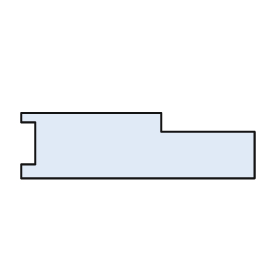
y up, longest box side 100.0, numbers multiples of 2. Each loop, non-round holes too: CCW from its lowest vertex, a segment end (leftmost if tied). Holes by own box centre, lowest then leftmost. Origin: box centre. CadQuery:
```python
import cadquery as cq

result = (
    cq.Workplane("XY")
    .moveTo(-50.0, -14.0)
    .lineTo(50.0, -14.0)
    .lineTo(50.0, 6.0)
    .lineTo(10.0, 6.0)
    .lineTo(10.0, 14.0)
    .lineTo(-50.0, 14.0)
    .lineTo(-50.0, 10.0)
    .lineTo(-44.0, 10.0)
    .lineTo(-44.0, -8.0)
    .lineTo(-50.0, -8.0)
    .close()
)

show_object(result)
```